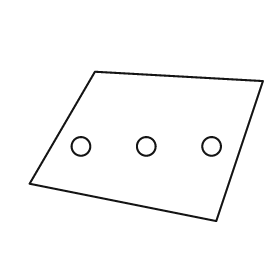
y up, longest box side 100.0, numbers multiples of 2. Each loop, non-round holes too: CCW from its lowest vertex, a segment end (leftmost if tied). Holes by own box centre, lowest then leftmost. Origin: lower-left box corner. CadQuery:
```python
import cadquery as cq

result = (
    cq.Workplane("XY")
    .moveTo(80.0, 0.0)
    .lineTo(100.0, 60.0)
    .lineTo(28.0, 64.0)
    .lineTo(0.0, 16.0)
    .close()
    .moveTo(22.0, 32.0)
    .circle(4.0)
    .moveTo(50.0, 32.0)
    .circle(4.0)
    .moveTo(78.0, 32.0)
    .circle(4.0)
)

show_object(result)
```